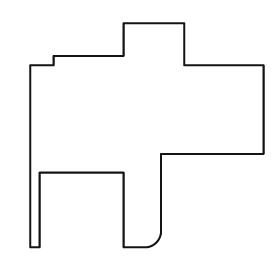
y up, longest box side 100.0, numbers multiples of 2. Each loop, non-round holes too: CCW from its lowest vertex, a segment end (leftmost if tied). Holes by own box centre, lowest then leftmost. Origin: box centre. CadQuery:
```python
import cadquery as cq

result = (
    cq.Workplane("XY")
    .moveTo(-50.0, -48.0)
    .lineTo(-46.0, -48.0)
    .lineTo(-46.0, -16.0)
    .lineTo(-10.0, -16.0)
    .lineTo(-10.0, -48.0)
    .lineTo(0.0, -48.0)
    .threePointArc((4.0, -46.0), (6.0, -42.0))
    .lineTo(6.0, -8.0)
    .lineTo(50.0, -8.0)
    .lineTo(50.0, 30.0)
    .lineTo(16.0, 30.0)
    .lineTo(16.0, 48.0)
    .lineTo(-10.0, 48.0)
    .lineTo(-10.0, 34.0)
    .lineTo(-40.0, 34.0)
    .lineTo(-40.0, 30.0)
    .lineTo(-50.0, 30.0)
    .close()
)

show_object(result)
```